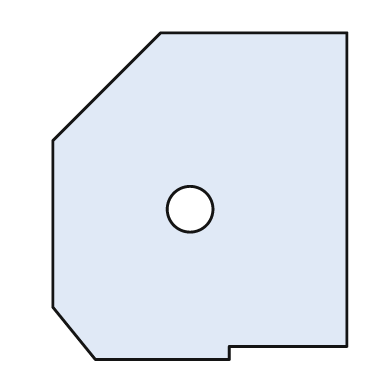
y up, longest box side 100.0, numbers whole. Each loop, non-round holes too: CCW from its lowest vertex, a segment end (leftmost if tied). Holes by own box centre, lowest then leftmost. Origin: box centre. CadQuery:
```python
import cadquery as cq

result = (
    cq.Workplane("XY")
    .moveTo(-32.0, -50.0)
    .lineTo(9.0, -50.0)
    .lineTo(9.0, -46.0)
    .lineTo(45.0, -46.0)
    .lineTo(45.0, 50.0)
    .lineTo(-12.0, 50.0)
    .lineTo(-45.0, 17.0)
    .lineTo(-45.0, -34.0)
    .close()
    .moveTo(-3.0, -4.0)
    .circle(7.0)
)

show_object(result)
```